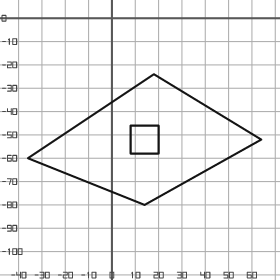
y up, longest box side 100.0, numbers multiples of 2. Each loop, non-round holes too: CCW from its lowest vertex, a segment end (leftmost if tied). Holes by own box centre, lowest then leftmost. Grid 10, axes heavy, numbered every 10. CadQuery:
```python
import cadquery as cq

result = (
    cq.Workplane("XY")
    .moveTo(14.0, -80.0)
    .lineTo(64.0, -52.0)
    .lineTo(18.0, -24.0)
    .lineTo(-36.0, -60.0)
    .close()
    .moveTo(8.0, -58.0)
    .lineTo(20.0, -58.0)
    .lineTo(20.0, -46.0)
    .lineTo(8.0, -46.0)
    .close()
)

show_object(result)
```